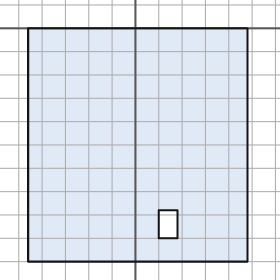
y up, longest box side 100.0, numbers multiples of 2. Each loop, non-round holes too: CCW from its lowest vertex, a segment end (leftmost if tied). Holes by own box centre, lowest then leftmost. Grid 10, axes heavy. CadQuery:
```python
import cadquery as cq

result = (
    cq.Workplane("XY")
    .moveTo(-46.0, -100.0)
    .lineTo(48.0, -100.0)
    .lineTo(48.0, 0.0)
    .lineTo(-46.0, 0.0)
    .close()
    .moveTo(10.0, -90.0)
    .lineTo(18.0, -90.0)
    .lineTo(18.0, -78.0)
    .lineTo(10.0, -78.0)
    .close()
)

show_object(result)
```